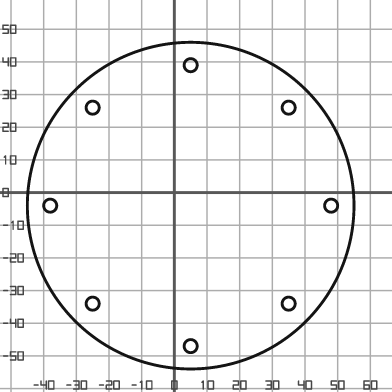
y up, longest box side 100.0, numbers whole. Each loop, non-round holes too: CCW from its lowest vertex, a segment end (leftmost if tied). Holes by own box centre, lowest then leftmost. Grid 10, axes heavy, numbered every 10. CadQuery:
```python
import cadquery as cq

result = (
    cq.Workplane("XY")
    .moveTo(5.0, -4.0)
    .circle(50.0)
    .moveTo(5.0, -47.0)
    .circle(2.0)
    .moveTo(-25.0, -34.0)
    .circle(2.0)
    .moveTo(35.0, -34.0)
    .circle(2.0)
    .moveTo(-38.0, -4.0)
    .circle(2.0)
    .moveTo(48.0, -4.0)
    .circle(2.0)
    .moveTo(-25.0, 26.0)
    .circle(2.0)
    .moveTo(35.0, 26.0)
    .circle(2.0)
    .moveTo(5.0, 39.0)
    .circle(2.0)
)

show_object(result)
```